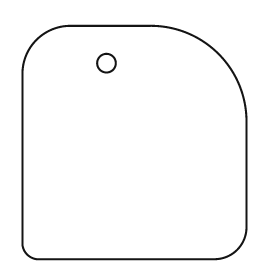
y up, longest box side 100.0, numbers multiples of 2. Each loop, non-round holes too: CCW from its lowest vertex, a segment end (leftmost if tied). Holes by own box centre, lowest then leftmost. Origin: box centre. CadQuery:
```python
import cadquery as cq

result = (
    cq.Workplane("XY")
    .moveTo(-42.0, -50.0)
    .lineTo(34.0, -50.0)
    .threePointArc((44.0, -46.0), (48.0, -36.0))
    .lineTo(48.0, 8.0)
    .threePointArc((36.0, 38.0), (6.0, 50.0))
    .lineTo(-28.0, 50.0)
    .threePointArc((-42.0, 44.0), (-48.0, 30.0))
    .lineTo(-48.0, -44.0)
    .threePointArc((-46.0, -48.0), (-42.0, -50.0))
    .close()
    .moveTo(-12.0, 34.0)
    .circle(4.0)
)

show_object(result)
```